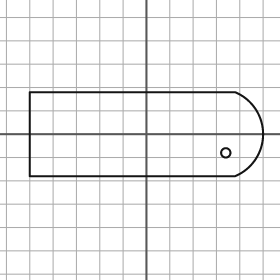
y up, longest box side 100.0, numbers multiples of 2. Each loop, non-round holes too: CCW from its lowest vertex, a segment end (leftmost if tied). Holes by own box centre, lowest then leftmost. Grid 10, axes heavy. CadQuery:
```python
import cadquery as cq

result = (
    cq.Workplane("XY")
    .moveTo(-50.0, -18.0)
    .lineTo(38.0, -18.0)
    .threePointArc((50.0, 0.0), (38.0, 18.0))
    .lineTo(-50.0, 18.0)
    .close()
    .moveTo(34.0, -8.0)
    .circle(2.0)
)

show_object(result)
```